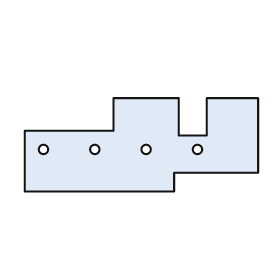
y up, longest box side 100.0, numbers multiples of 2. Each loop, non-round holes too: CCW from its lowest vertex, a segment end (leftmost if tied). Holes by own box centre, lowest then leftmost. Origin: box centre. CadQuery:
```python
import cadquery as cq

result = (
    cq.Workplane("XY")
    .moveTo(-50.0, -20.0)
    .lineTo(14.0, -20.0)
    .lineTo(14.0, -12.0)
    .lineTo(50.0, -12.0)
    .lineTo(50.0, 20.0)
    .lineTo(28.0, 20.0)
    .lineTo(28.0, 4.0)
    .lineTo(16.0, 4.0)
    .lineTo(16.0, 20.0)
    .lineTo(-12.0, 20.0)
    .lineTo(-12.0, 6.0)
    .lineTo(-50.0, 6.0)
    .close()
    .moveTo(-42.0, -2.0)
    .circle(2.0)
    .moveTo(-20.0, -2.0)
    .circle(2.0)
    .moveTo(2.0, -2.0)
    .circle(2.0)
    .moveTo(24.0, -2.0)
    .circle(2.0)
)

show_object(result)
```